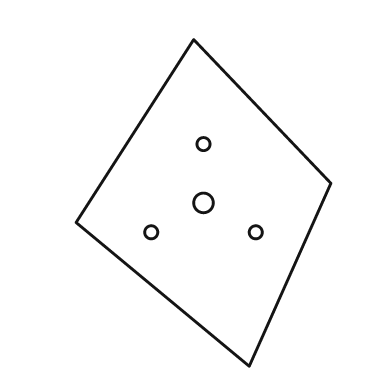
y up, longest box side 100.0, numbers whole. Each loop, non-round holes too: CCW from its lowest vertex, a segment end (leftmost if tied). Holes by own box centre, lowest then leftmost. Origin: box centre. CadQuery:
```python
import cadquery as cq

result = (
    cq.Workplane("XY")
    .moveTo(14.0, -50.0)
    .lineTo(39.0, 6.0)
    .lineTo(-3.0, 50.0)
    .lineTo(-39.0, -6.0)
    .close()
    .moveTo(-16.0, -9.0)
    .circle(2.0)
    .moveTo(16.0, -9.0)
    .circle(2.0)
    .moveTo(0.0, 0.0)
    .circle(3.0)
    .moveTo(0.0, 18.0)
    .circle(2.0)
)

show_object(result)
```